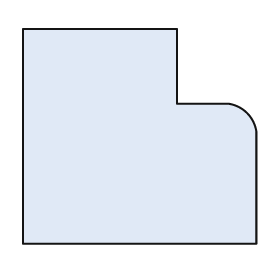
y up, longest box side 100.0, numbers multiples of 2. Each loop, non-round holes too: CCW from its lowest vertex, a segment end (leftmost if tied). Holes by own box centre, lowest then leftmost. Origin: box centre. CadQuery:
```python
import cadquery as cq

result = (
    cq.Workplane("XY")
    .moveTo(-50.0, -46.0)
    .lineTo(50.0, -46.0)
    .lineTo(50.0, 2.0)
    .threePointArc((46.0, 10.0), (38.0, 14.0))
    .lineTo(16.0, 14.0)
    .lineTo(16.0, 46.0)
    .lineTo(-50.0, 46.0)
    .close()
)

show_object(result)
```